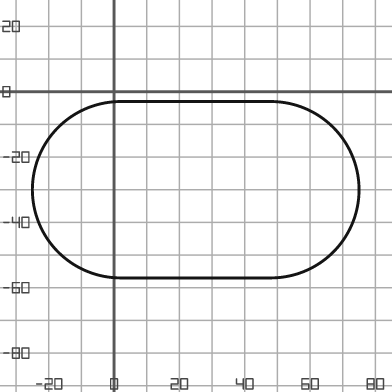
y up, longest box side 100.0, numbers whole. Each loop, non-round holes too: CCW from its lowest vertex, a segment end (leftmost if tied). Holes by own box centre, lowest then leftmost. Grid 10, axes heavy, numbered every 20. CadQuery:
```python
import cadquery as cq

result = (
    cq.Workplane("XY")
    .moveTo(2.0, -57.0)
    .lineTo(48.0, -57.0)
    .threePointArc((75.0, -30.0), (48.0, -3.0))
    .lineTo(2.0, -3.0)
    .threePointArc((-25.0, -30.0), (2.0, -57.0))
    .close()
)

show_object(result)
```